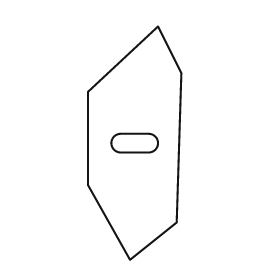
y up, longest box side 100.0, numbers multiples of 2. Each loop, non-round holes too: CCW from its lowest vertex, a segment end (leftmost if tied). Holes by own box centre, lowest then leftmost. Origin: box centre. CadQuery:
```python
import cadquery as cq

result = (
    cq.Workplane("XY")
    .moveTo(-2.0, -50.0)
    .lineTo(18.0, -34.0)
    .lineTo(20.0, 30.0)
    .lineTo(10.0, 50.0)
    .lineTo(-20.0, 22.0)
    .lineTo(-20.0, -18.0)
    .close()
    .moveTo(-6.0, -4.0)
    .lineTo(6.0, -4.0)
    .threePointArc((10.0, 0.0), (6.0, 4.0))
    .lineTo(-6.0, 4.0)
    .threePointArc((-10.0, 0.0), (-6.0, -4.0))
    .close()
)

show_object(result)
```